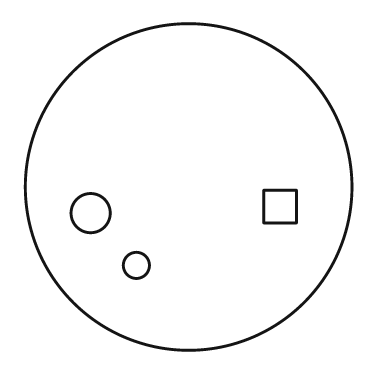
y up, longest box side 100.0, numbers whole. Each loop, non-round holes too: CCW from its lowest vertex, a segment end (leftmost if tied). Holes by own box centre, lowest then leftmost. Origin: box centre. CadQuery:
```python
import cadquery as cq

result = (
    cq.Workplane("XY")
    .moveTo(0.0, 0.0)
    .circle(50.0)
    .moveTo(-16.0, -24.0)
    .circle(4.0)
    .moveTo(-30.0, -8.0)
    .circle(6.0)
    .moveTo(23.0, -11.0)
    .lineTo(33.0, -11.0)
    .lineTo(33.0, -1.0)
    .lineTo(23.0, -1.0)
    .close()
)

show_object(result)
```